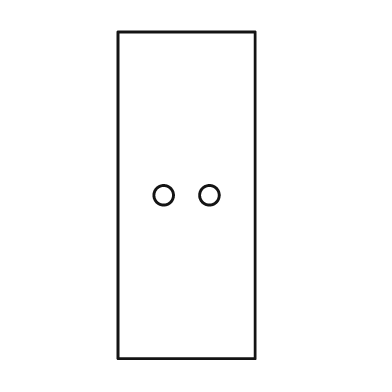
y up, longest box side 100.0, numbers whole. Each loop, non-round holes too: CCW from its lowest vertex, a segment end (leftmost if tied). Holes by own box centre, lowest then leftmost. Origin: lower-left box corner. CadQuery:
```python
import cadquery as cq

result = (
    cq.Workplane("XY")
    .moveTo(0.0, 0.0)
    .lineTo(42.0, 0.0)
    .lineTo(42.0, 100.0)
    .lineTo(0.0, 100.0)
    .close()
    .moveTo(14.0, 50.0)
    .circle(3.0)
    .moveTo(28.0, 50.0)
    .circle(3.0)
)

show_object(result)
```